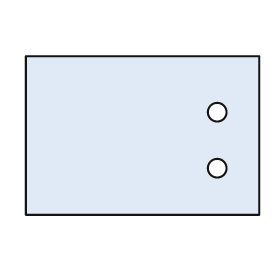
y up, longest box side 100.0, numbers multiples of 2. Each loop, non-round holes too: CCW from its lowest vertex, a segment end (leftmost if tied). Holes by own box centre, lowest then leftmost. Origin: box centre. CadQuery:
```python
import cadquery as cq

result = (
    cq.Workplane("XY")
    .moveTo(-50.0, -34.0)
    .lineTo(50.0, -34.0)
    .lineTo(50.0, 34.0)
    .lineTo(-50.0, 34.0)
    .close()
    .moveTo(32.0, -14.0)
    .circle(4.0)
    .moveTo(32.0, 10.0)
    .circle(4.0)
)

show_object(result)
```